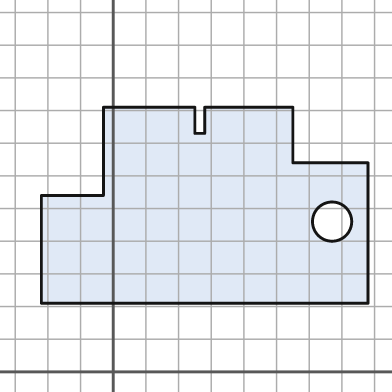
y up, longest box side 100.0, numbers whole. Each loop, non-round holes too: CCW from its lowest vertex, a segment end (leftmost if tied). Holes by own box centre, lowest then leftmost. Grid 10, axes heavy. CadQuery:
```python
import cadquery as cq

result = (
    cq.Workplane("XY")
    .moveTo(-22.0, 21.0)
    .lineTo(78.0, 21.0)
    .lineTo(78.0, 64.0)
    .lineTo(55.0, 64.0)
    .lineTo(55.0, 81.0)
    .lineTo(28.0, 81.0)
    .lineTo(28.0, 73.0)
    .lineTo(25.0, 73.0)
    .lineTo(25.0, 81.0)
    .lineTo(-3.0, 81.0)
    .lineTo(-3.0, 54.0)
    .lineTo(-22.0, 54.0)
    .close()
    .moveTo(67.0, 46.0)
    .circle(6.0)
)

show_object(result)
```